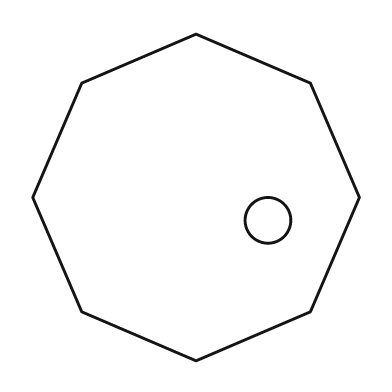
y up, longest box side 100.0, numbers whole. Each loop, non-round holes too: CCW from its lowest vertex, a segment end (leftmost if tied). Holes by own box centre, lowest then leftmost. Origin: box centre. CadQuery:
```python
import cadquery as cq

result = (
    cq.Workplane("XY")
    .moveTo(0.0, -50.0)
    .lineTo(35.0, -35.0)
    .lineTo(50.0, 0.0)
    .lineTo(35.0, 35.0)
    .lineTo(0.0, 50.0)
    .lineTo(-35.0, 35.0)
    .lineTo(-50.0, 0.0)
    .lineTo(-35.0, -35.0)
    .close()
    .moveTo(22.0, -7.0)
    .circle(7.0)
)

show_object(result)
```